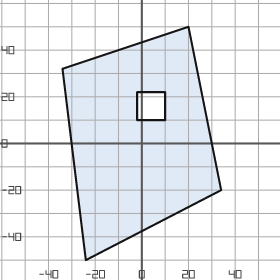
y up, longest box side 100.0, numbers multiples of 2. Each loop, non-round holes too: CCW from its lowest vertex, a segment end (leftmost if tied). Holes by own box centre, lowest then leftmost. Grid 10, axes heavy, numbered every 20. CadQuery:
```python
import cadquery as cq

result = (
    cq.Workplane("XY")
    .moveTo(-24.0, -50.0)
    .lineTo(34.0, -20.0)
    .lineTo(20.0, 50.0)
    .lineTo(-34.0, 32.0)
    .close()
    .moveTo(-2.0, 10.0)
    .lineTo(10.0, 10.0)
    .lineTo(10.0, 22.0)
    .lineTo(-2.0, 22.0)
    .close()
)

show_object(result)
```